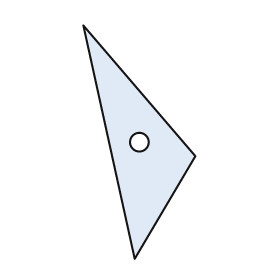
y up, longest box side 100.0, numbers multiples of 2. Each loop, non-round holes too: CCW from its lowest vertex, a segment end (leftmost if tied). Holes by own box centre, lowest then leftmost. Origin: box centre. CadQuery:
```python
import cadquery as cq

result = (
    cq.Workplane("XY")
    .moveTo(-2.0, -50.0)
    .lineTo(24.0, -6.0)
    .lineTo(-24.0, 50.0)
    .close()
    .moveTo(0.0, 0.0)
    .circle(4.0)
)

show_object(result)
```